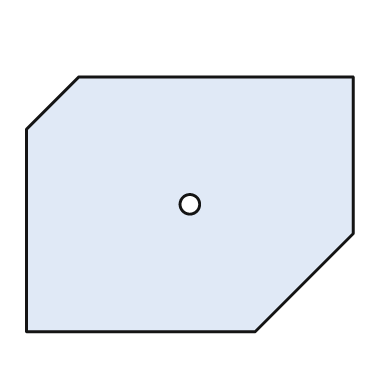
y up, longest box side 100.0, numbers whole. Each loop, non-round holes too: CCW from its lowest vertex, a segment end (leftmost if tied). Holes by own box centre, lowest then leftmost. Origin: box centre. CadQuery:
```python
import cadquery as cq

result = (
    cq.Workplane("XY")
    .moveTo(-50.0, -39.0)
    .lineTo(20.0, -39.0)
    .lineTo(50.0, -9.0)
    .lineTo(50.0, 39.0)
    .lineTo(-34.0, 39.0)
    .lineTo(-50.0, 23.0)
    .close()
    .moveTo(0.0, 0.0)
    .circle(3.0)
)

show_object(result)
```